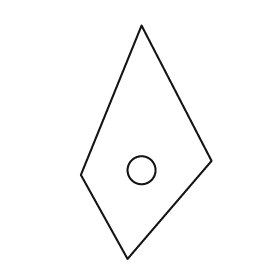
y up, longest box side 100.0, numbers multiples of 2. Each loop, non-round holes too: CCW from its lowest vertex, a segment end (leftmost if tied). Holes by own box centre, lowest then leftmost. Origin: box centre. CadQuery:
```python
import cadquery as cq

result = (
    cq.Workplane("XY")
    .moveTo(-8.0, -50.0)
    .lineTo(28.0, -8.0)
    .lineTo(-2.0, 50.0)
    .lineTo(-28.0, -14.0)
    .close()
    .moveTo(-2.0, -12.0)
    .circle(6.0)
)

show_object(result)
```